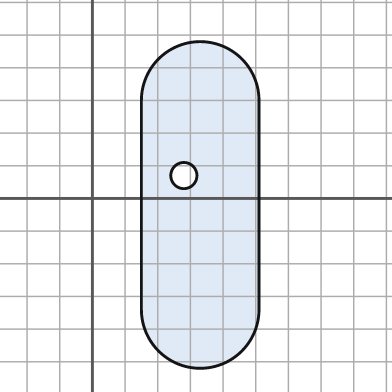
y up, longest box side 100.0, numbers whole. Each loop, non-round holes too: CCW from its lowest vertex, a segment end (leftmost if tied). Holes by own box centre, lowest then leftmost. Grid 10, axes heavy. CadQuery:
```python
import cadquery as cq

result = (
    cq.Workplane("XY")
    .moveTo(15.0, -34.0)
    .threePointArc((33.0, -52.0), (51.0, -34.0))
    .lineTo(51.0, 30.0)
    .threePointArc((33.0, 48.0), (15.0, 30.0))
    .close()
    .moveTo(28.0, 7.0)
    .circle(4.0)
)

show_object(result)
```